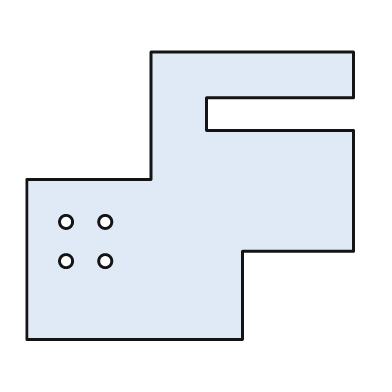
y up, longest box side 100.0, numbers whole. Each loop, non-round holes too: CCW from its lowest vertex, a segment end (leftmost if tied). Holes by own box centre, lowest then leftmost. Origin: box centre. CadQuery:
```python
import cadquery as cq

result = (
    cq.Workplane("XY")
    .moveTo(-50.0, -44.0)
    .lineTo(16.0, -44.0)
    .lineTo(16.0, -17.0)
    .lineTo(50.0, -17.0)
    .lineTo(50.0, 20.0)
    .lineTo(5.0, 20.0)
    .lineTo(5.0, 30.0)
    .lineTo(50.0, 30.0)
    .lineTo(50.0, 44.0)
    .lineTo(-12.0, 44.0)
    .lineTo(-12.0, 5.0)
    .lineTo(-50.0, 5.0)
    .close()
    .moveTo(-38.0, -20.0)
    .circle(2.0)
    .moveTo(-26.0, -20.0)
    .circle(2.0)
    .moveTo(-38.0, -8.0)
    .circle(2.0)
    .moveTo(-26.0, -8.0)
    .circle(2.0)
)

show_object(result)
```